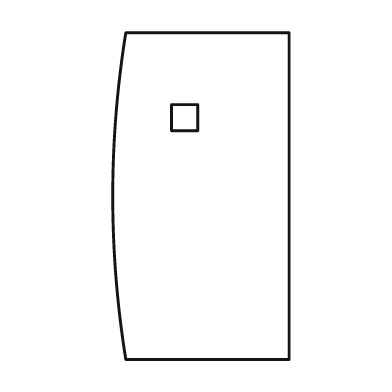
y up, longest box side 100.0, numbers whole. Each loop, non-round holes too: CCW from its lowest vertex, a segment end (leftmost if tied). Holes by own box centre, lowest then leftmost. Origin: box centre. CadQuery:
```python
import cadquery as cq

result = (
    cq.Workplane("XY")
    .moveTo(-23.0, -50.0)
    .lineTo(27.0, -50.0)
    .lineTo(27.0, 50.0)
    .lineTo(-23.0, 50.0)
    .threePointArc((-27.0, 0.0), (-23.0, -50.0))
    .close()
    .moveTo(-9.0, 20.0)
    .lineTo(-1.0, 20.0)
    .lineTo(-1.0, 28.0)
    .lineTo(-9.0, 28.0)
    .close()
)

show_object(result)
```